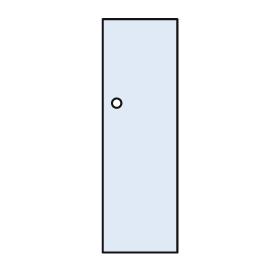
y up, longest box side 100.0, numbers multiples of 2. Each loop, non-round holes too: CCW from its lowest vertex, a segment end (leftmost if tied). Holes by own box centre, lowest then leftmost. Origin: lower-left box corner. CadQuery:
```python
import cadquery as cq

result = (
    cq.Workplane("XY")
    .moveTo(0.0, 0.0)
    .lineTo(32.0, 0.0)
    .lineTo(32.0, 100.0)
    .lineTo(0.0, 100.0)
    .close()
    .moveTo(6.0, 64.0)
    .circle(2.0)
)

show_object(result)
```